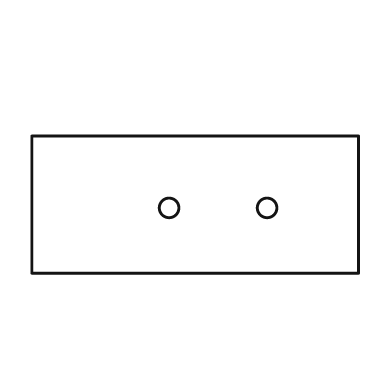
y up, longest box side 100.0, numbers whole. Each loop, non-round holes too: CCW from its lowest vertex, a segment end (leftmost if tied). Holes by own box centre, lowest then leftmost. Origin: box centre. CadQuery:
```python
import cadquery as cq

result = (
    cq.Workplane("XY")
    .moveTo(-50.0, -21.0)
    .lineTo(50.0, -21.0)
    .lineTo(50.0, 21.0)
    .lineTo(-50.0, 21.0)
    .close()
    .moveTo(-8.0, -1.0)
    .circle(3.0)
    .moveTo(22.0, -1.0)
    .circle(3.0)
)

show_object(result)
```